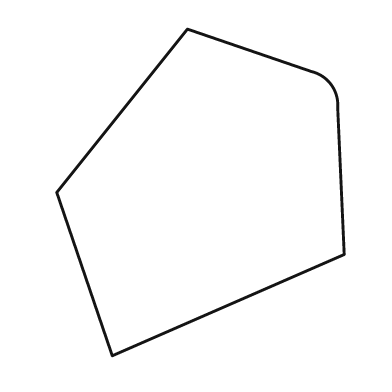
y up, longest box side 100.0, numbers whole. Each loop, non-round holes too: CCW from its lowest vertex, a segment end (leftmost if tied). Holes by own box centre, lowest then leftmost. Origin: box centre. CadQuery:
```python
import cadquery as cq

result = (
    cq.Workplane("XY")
    .moveTo(-27.0, -50.0)
    .lineTo(44.0, -19.0)
    .lineTo(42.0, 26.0)
    .threePointArc((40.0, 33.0), (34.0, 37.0))
    .lineTo(-4.0, 50.0)
    .lineTo(-44.0, 0.0)
    .close()
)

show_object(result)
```